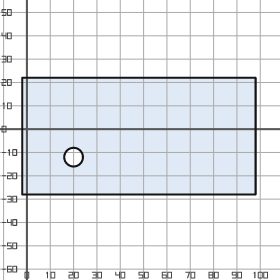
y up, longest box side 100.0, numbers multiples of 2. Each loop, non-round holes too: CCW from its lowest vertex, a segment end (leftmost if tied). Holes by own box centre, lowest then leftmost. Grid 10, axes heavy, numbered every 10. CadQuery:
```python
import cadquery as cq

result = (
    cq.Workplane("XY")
    .moveTo(-2.0, -28.0)
    .lineTo(98.0, -28.0)
    .lineTo(98.0, 22.0)
    .lineTo(-2.0, 22.0)
    .close()
    .moveTo(20.0, -12.0)
    .circle(4.0)
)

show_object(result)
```